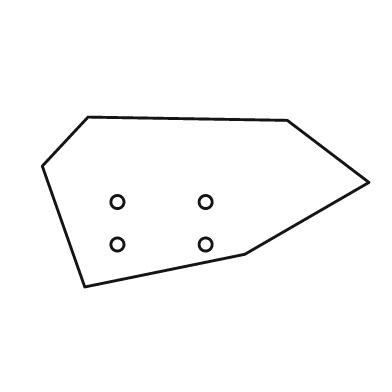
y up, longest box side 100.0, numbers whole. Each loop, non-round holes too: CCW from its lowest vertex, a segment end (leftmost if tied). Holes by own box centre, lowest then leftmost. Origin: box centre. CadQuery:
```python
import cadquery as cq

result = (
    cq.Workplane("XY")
    .moveTo(-37.0, -26.0)
    .lineTo(12.0, -16.0)
    .lineTo(50.0, 6.0)
    .lineTo(25.0, 25.0)
    .lineTo(-36.0, 26.0)
    .lineTo(-50.0, 11.0)
    .close()
    .moveTo(-27.0, -13.0)
    .circle(2.0)
    .moveTo(0.0, -13.0)
    .circle(2.0)
    .moveTo(-27.0, 0.0)
    .circle(2.0)
    .moveTo(0.0, 0.0)
    .circle(2.0)
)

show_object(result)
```